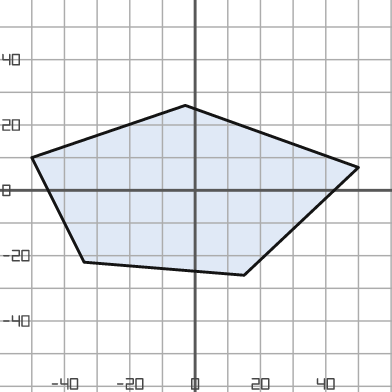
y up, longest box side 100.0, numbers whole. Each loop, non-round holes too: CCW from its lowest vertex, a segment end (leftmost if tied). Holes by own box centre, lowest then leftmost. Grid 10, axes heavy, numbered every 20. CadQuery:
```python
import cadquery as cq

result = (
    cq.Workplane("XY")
    .moveTo(15.0, -26.0)
    .lineTo(50.0, 7.0)
    .lineTo(-3.0, 26.0)
    .lineTo(-50.0, 10.0)
    .lineTo(-34.0, -22.0)
    .close()
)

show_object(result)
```